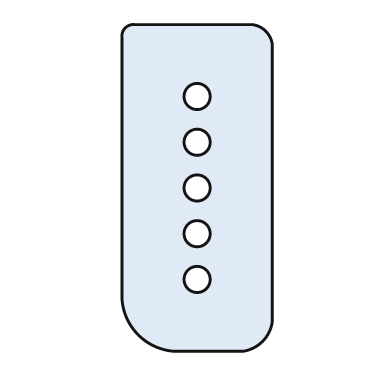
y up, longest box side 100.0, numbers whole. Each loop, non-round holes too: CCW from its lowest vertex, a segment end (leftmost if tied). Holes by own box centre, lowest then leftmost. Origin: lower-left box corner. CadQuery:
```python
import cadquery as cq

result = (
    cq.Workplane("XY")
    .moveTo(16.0, 0.0)
    .lineTo(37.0, 0.0)
    .threePointArc((43.0, 3.0), (46.0, 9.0))
    .lineTo(46.0, 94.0)
    .threePointArc((44.0, 98.0), (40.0, 100.0))
    .lineTo(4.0, 100.0)
    .threePointArc((1.0, 99.0), (0.0, 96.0))
    .lineTo(0.0, 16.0)
    .threePointArc((5.0, 5.0), (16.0, 0.0))
    .close()
    .moveTo(23.0, 22.0)
    .circle(4.0)
    .moveTo(23.0, 36.0)
    .circle(4.0)
    .moveTo(23.0, 50.0)
    .circle(4.0)
    .moveTo(23.0, 64.0)
    .circle(4.0)
    .moveTo(23.0, 78.0)
    .circle(4.0)
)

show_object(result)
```